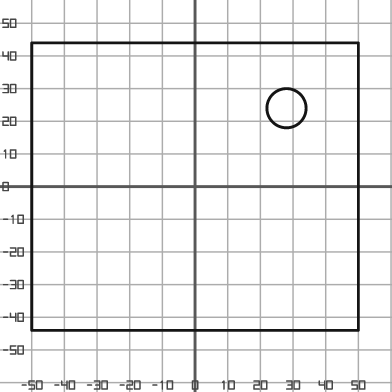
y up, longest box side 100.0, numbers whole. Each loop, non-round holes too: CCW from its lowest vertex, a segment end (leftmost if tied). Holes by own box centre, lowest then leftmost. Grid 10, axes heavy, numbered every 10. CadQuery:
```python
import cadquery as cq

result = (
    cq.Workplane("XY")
    .moveTo(-50.0, -44.0)
    .lineTo(50.0, -44.0)
    .lineTo(50.0, 44.0)
    .lineTo(-50.0, 44.0)
    .close()
    .moveTo(28.0, 24.0)
    .circle(6.0)
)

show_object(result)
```